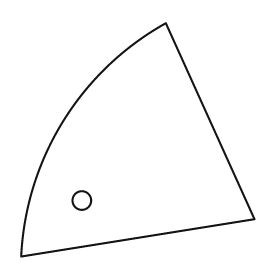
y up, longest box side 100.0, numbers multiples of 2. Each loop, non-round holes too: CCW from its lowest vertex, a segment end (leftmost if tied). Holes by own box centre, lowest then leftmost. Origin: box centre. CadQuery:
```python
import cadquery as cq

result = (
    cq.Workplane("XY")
    .moveTo(-50.0, -50.0)
    .lineTo(50.0, -34.0)
    .lineTo(12.0, 50.0)
    .threePointArc((-32.0, 8.0), (-50.0, -50.0))
    .close()
    .moveTo(-24.0, -26.0)
    .circle(4.0)
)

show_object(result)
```